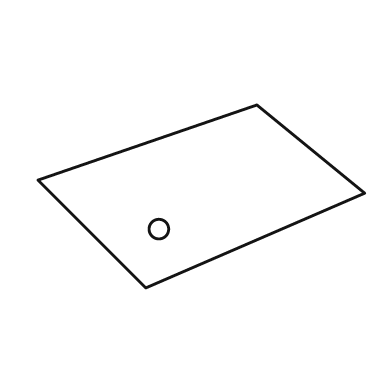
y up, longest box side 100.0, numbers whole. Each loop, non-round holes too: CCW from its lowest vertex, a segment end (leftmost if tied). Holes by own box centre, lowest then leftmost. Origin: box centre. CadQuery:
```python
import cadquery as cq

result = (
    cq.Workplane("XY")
    .moveTo(-17.0, -28.0)
    .lineTo(50.0, 1.0)
    .lineTo(17.0, 28.0)
    .lineTo(-50.0, 5.0)
    .close()
    .moveTo(-13.0, -10.0)
    .circle(3.0)
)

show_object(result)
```